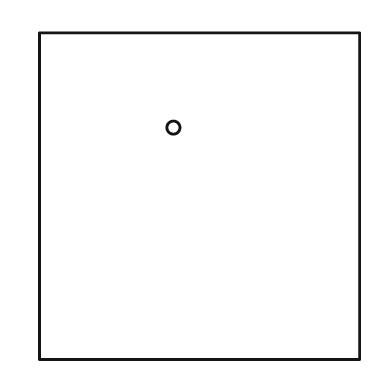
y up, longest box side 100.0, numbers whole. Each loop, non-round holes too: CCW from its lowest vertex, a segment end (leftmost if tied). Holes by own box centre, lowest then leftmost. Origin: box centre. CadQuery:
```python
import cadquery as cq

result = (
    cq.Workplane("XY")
    .moveTo(-49.0, -50.0)
    .lineTo(49.0, -50.0)
    .lineTo(49.0, 50.0)
    .lineTo(-49.0, 50.0)
    .close()
    .moveTo(-8.0, 21.0)
    .circle(2.0)
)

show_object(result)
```